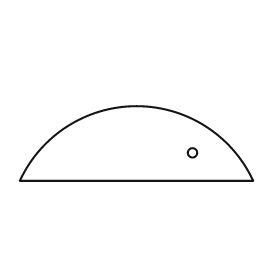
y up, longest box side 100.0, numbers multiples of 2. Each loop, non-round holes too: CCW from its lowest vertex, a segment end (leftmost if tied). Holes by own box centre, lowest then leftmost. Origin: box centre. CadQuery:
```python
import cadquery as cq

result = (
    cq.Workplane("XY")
    .moveTo(-50.0, -16.0)
    .lineTo(50.0, -16.0)
    .threePointArc((0.0, 16.0), (-50.0, -16.0))
    .close()
    .moveTo(24.0, -4.0)
    .circle(2.0)
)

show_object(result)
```